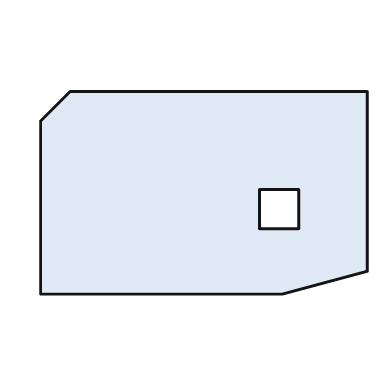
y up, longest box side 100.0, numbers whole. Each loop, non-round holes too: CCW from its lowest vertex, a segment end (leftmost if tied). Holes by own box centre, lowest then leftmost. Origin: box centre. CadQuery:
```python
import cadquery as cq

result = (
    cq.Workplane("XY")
    .moveTo(-50.0, -31.0)
    .lineTo(24.0, -31.0)
    .lineTo(50.0, -24.0)
    .lineTo(50.0, 31.0)
    .lineTo(-41.0, 31.0)
    .lineTo(-50.0, 22.0)
    .close()
    .moveTo(17.0, -11.0)
    .lineTo(29.0, -11.0)
    .lineTo(29.0, 1.0)
    .lineTo(17.0, 1.0)
    .close()
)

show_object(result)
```